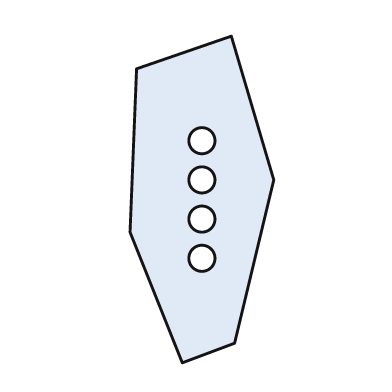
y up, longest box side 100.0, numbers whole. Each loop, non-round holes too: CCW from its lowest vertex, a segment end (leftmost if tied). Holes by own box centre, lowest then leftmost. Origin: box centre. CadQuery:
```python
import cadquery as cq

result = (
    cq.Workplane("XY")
    .moveTo(-6.0, -50.0)
    .lineTo(10.0, -44.0)
    .lineTo(22.0, 6.0)
    .lineTo(9.0, 50.0)
    .lineTo(-20.0, 40.0)
    .lineTo(-22.0, -10.0)
    .close()
    .moveTo(0.0, -18.0)
    .circle(4.0)
    .moveTo(0.0, -6.0)
    .circle(4.0)
    .moveTo(0.0, 6.0)
    .circle(4.0)
    .moveTo(0.0, 18.0)
    .circle(4.0)
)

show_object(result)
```